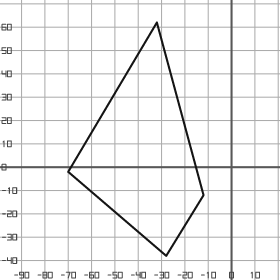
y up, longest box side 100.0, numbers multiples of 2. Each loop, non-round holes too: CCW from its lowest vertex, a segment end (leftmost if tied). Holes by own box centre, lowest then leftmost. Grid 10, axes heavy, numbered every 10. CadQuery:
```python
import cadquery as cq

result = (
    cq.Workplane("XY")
    .moveTo(-28.0, -38.0)
    .lineTo(-12.0, -12.0)
    .lineTo(-32.0, 62.0)
    .lineTo(-70.0, -2.0)
    .close()
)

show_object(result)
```